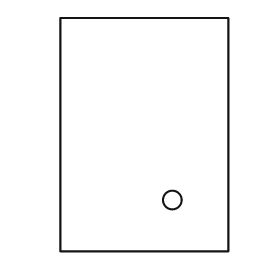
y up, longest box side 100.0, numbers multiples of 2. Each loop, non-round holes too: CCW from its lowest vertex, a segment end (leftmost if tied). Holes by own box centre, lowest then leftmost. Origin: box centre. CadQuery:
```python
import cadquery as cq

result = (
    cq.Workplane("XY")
    .moveTo(-36.0, -50.0)
    .lineTo(36.0, -50.0)
    .lineTo(36.0, 50.0)
    .lineTo(-36.0, 50.0)
    .close()
    .moveTo(12.0, -28.0)
    .circle(4.0)
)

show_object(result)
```